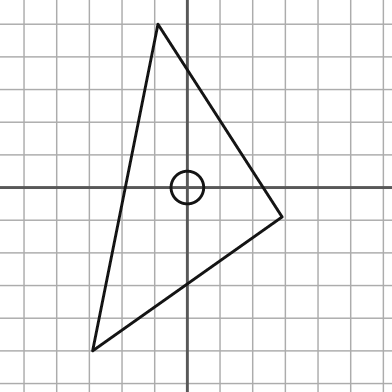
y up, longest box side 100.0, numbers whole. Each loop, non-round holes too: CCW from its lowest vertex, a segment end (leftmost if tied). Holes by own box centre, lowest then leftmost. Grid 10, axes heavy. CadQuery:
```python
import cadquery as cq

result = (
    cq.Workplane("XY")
    .moveTo(-29.0, -50.0)
    .lineTo(29.0, -9.0)
    .lineTo(-9.0, 50.0)
    .close()
    .moveTo(0.0, 0.0)
    .circle(5.0)
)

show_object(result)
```